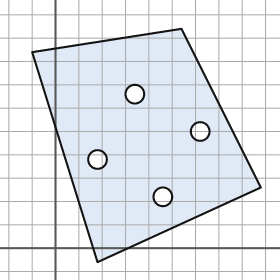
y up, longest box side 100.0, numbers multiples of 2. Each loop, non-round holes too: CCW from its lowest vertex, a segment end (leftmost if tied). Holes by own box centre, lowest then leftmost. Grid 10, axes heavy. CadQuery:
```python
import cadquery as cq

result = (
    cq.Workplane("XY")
    .moveTo(18.0, -6.0)
    .lineTo(88.0, 26.0)
    .lineTo(54.0, 94.0)
    .lineTo(-10.0, 84.0)
    .close()
    .moveTo(46.0, 22.0)
    .circle(4.0)
    .moveTo(18.0, 38.0)
    .circle(4.0)
    .moveTo(62.0, 50.0)
    .circle(4.0)
    .moveTo(34.0, 66.0)
    .circle(4.0)
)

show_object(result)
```